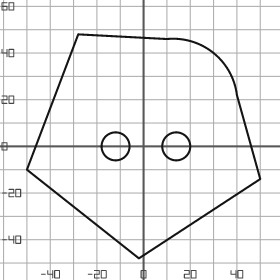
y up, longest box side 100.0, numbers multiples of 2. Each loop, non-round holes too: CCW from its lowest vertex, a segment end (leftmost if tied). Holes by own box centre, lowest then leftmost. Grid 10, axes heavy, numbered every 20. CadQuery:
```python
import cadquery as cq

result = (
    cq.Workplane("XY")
    .moveTo(-2.0, -48.0)
    .lineTo(50.0, -14.0)
    .lineTo(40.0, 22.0)
    .threePointArc((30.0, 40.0), (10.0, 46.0))
    .lineTo(-28.0, 48.0)
    .lineTo(-50.0, -10.0)
    .close()
    .moveTo(-12.0, 0.0)
    .circle(6.0)
    .moveTo(14.0, 0.0)
    .circle(6.0)
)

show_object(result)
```